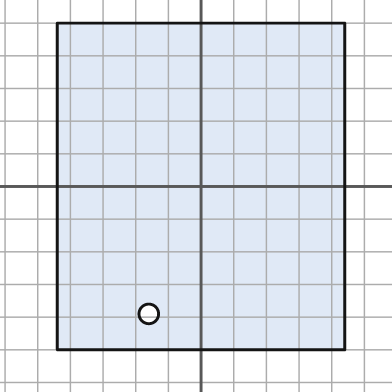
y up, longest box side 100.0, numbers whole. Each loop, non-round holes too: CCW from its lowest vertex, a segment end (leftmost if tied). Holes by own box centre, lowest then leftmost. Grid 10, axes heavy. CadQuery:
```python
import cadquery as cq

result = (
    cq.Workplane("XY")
    .moveTo(-44.0, -50.0)
    .lineTo(44.0, -50.0)
    .lineTo(44.0, 50.0)
    .lineTo(-44.0, 50.0)
    .close()
    .moveTo(-16.0, -39.0)
    .circle(3.0)
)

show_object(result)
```